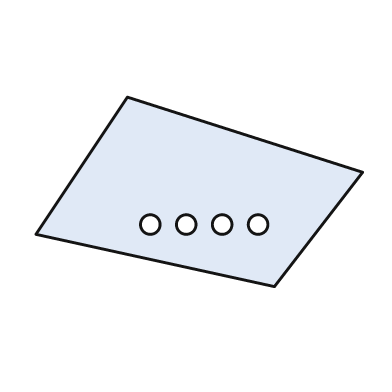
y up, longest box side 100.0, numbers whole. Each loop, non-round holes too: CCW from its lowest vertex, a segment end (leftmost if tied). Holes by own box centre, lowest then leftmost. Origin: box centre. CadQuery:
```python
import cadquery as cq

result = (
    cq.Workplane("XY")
    .moveTo(23.0, -29.0)
    .lineTo(50.0, 6.0)
    .lineTo(-22.0, 29.0)
    .lineTo(-50.0, -13.0)
    .close()
    .moveTo(-15.0, -10.0)
    .circle(3.0)
    .moveTo(-4.0, -10.0)
    .circle(3.0)
    .moveTo(7.0, -10.0)
    .circle(3.0)
    .moveTo(18.0, -10.0)
    .circle(3.0)
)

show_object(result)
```